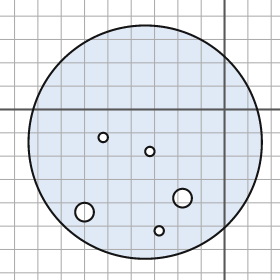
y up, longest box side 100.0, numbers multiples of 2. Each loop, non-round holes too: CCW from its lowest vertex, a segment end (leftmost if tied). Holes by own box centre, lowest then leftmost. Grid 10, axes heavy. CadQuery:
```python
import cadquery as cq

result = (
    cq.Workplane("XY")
    .moveTo(-34.0, -14.0)
    .circle(50.0)
    .moveTo(-28.0, -52.0)
    .circle(2.0)
    .moveTo(-60.0, -44.0)
    .circle(4.0)
    .moveTo(-18.0, -38.0)
    .circle(4.0)
    .moveTo(-32.0, -18.0)
    .circle(2.0)
    .moveTo(-52.0, -12.0)
    .circle(2.0)
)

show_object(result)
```